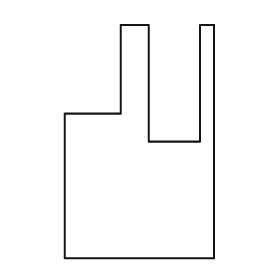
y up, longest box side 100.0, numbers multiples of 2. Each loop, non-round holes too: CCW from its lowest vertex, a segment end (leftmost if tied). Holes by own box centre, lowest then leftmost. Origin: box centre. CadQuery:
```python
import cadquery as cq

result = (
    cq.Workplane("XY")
    .moveTo(-32.0, -50.0)
    .lineTo(32.0, -50.0)
    .lineTo(32.0, 50.0)
    .lineTo(26.0, 50.0)
    .lineTo(26.0, 0.0)
    .lineTo(4.0, 0.0)
    .lineTo(4.0, 50.0)
    .lineTo(-8.0, 50.0)
    .lineTo(-8.0, 12.0)
    .lineTo(-32.0, 12.0)
    .close()
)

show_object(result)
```